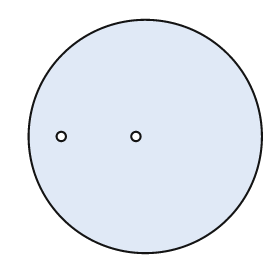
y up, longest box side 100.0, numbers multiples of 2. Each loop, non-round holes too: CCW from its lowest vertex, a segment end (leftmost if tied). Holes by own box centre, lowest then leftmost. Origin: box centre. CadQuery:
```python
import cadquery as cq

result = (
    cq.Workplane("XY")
    .moveTo(0.0, 0.0)
    .circle(50.0)
    .moveTo(-36.0, 0.0)
    .circle(2.0)
    .moveTo(-4.0, 0.0)
    .circle(2.0)
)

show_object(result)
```